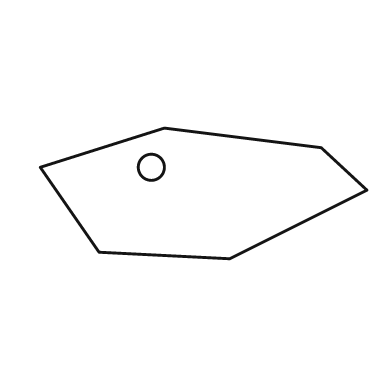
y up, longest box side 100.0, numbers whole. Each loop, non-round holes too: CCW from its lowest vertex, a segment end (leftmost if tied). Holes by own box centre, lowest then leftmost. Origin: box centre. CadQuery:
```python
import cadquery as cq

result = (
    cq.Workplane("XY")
    .moveTo(8.0, -20.0)
    .lineTo(50.0, 1.0)
    .lineTo(36.0, 14.0)
    .lineTo(-12.0, 20.0)
    .lineTo(-50.0, 8.0)
    .lineTo(-32.0, -18.0)
    .close()
    .moveTo(-16.0, 8.0)
    .circle(4.0)
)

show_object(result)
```